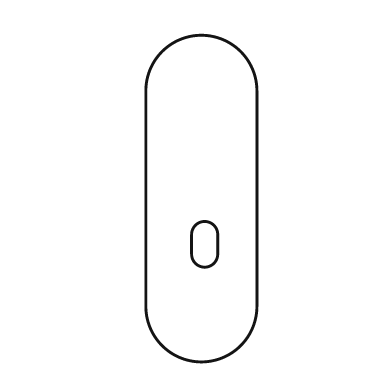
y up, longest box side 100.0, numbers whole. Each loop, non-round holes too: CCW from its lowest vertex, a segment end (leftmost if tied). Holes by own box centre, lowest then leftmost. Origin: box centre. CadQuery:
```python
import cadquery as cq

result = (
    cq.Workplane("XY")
    .moveTo(-17.0, -33.0)
    .threePointArc((0.0, -50.0), (17.0, -33.0))
    .lineTo(17.0, 33.0)
    .threePointArc((0.0, 50.0), (-17.0, 33.0))
    .close()
    .moveTo(-3.0, -17.0)
    .threePointArc((1.0, -21.0), (5.0, -17.0))
    .lineTo(5.0, -11.0)
    .threePointArc((1.0, -7.0), (-3.0, -11.0))
    .close()
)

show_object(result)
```